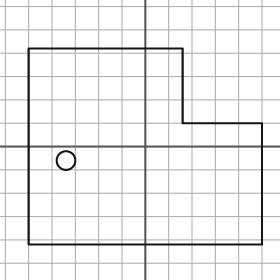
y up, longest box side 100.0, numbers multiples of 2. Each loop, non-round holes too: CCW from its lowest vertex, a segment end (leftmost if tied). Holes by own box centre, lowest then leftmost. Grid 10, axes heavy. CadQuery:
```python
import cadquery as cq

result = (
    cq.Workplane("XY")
    .moveTo(-50.0, -42.0)
    .lineTo(50.0, -42.0)
    .lineTo(50.0, 10.0)
    .lineTo(16.0, 10.0)
    .lineTo(16.0, 42.0)
    .lineTo(-50.0, 42.0)
    .close()
    .moveTo(-34.0, -6.0)
    .circle(4.0)
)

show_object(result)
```